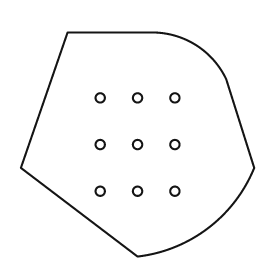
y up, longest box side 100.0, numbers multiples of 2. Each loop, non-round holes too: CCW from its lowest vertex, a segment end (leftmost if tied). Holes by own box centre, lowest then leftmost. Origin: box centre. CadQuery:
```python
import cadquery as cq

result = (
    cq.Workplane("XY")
    .moveTo(0.0, -48.0)
    .threePointArc((30.0, -36.0), (50.0, -10.0))
    .lineTo(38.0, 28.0)
    .threePointArc((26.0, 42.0), (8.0, 48.0))
    .lineTo(-30.0, 48.0)
    .lineTo(-50.0, -10.0)
    .close()
    .moveTo(-16.0, -20.0)
    .circle(2.0)
    .moveTo(0.0, -20.0)
    .circle(2.0)
    .moveTo(16.0, -20.0)
    .circle(2.0)
    .moveTo(-16.0, 0.0)
    .circle(2.0)
    .moveTo(0.0, 0.0)
    .circle(2.0)
    .moveTo(16.0, 0.0)
    .circle(2.0)
    .moveTo(-16.0, 20.0)
    .circle(2.0)
    .moveTo(0.0, 20.0)
    .circle(2.0)
    .moveTo(16.0, 20.0)
    .circle(2.0)
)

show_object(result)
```